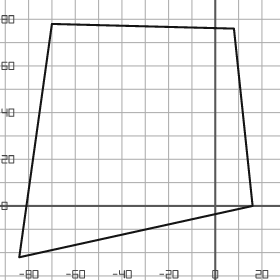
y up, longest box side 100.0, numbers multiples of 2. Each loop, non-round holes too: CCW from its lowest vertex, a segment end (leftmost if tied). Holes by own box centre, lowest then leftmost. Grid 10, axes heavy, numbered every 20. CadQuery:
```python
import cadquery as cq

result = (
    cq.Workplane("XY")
    .moveTo(-84.0, -22.0)
    .lineTo(16.0, 0.0)
    .lineTo(8.0, 76.0)
    .lineTo(-70.0, 78.0)
    .close()
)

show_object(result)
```